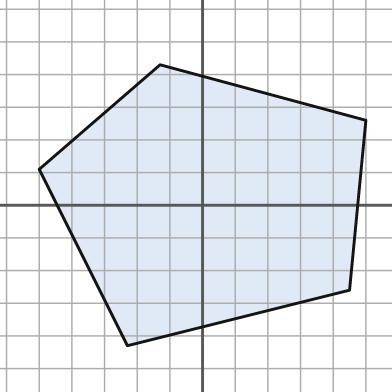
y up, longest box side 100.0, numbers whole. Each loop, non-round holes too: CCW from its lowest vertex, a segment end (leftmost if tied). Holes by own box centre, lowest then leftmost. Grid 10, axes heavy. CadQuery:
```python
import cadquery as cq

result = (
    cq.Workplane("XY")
    .moveTo(-23.0, -43.0)
    .lineTo(45.0, -26.0)
    .lineTo(50.0, 26.0)
    .lineTo(-13.0, 43.0)
    .lineTo(-50.0, 11.0)
    .close()
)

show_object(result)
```